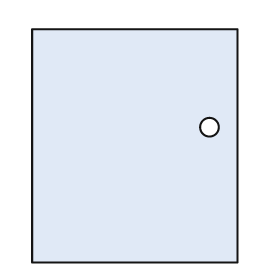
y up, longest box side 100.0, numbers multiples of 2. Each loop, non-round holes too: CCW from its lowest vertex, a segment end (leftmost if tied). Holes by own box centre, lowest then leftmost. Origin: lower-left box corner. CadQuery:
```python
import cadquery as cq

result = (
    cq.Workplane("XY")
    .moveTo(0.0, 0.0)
    .lineTo(88.0, 0.0)
    .lineTo(88.0, 100.0)
    .lineTo(0.0, 100.0)
    .close()
    .moveTo(76.0, 58.0)
    .circle(4.0)
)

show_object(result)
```